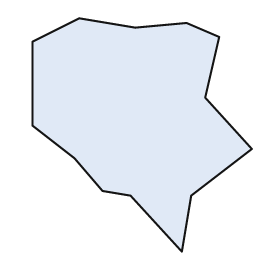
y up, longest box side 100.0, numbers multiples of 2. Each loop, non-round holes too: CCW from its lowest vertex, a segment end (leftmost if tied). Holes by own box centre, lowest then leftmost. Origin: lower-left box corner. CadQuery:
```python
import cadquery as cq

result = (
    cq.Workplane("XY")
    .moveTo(64.0, 0.0)
    .lineTo(68.0, 24.0)
    .lineTo(94.0, 44.0)
    .lineTo(74.0, 66.0)
    .lineTo(80.0, 92.0)
    .lineTo(66.0, 98.0)
    .lineTo(44.0, 96.0)
    .lineTo(20.0, 100.0)
    .lineTo(0.0, 90.0)
    .lineTo(0.0, 54.0)
    .lineTo(18.0, 40.0)
    .lineTo(30.0, 26.0)
    .lineTo(42.0, 24.0)
    .close()
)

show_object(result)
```